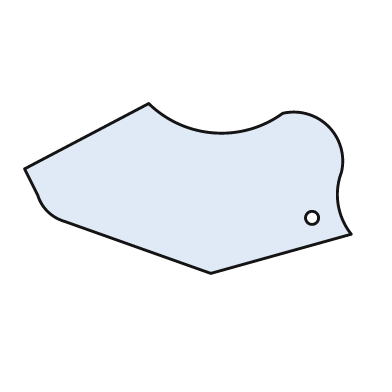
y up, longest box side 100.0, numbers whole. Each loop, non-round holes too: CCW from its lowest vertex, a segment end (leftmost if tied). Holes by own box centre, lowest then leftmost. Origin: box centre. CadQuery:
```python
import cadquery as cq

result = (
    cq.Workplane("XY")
    .moveTo(7.0, -26.0)
    .lineTo(50.0, -14.0)
    .threePointArc((46.0, -5.0), (47.0, 5.0))
    .threePointArc((43.0, 19.0), (29.0, 23.0))
    .threePointArc((8.0, 17.0), (-12.0, 26.0))
    .lineTo(-50.0, 6.0)
    .lineTo(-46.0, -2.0)
    .threePointArc((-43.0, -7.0), (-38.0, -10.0))
    .close()
    .moveTo(38.0, -9.0)
    .circle(2.0)
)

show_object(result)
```